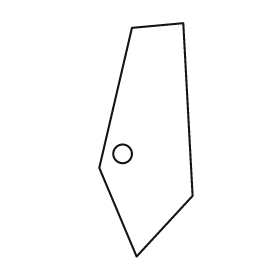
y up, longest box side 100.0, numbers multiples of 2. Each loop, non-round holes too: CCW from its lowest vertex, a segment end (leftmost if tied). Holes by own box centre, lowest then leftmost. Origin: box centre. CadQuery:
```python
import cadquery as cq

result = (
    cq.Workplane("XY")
    .moveTo(-4.0, -50.0)
    .lineTo(20.0, -24.0)
    .lineTo(16.0, 50.0)
    .lineTo(-6.0, 48.0)
    .lineTo(-20.0, -12.0)
    .close()
    .moveTo(-10.0, -6.0)
    .circle(4.0)
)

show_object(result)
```